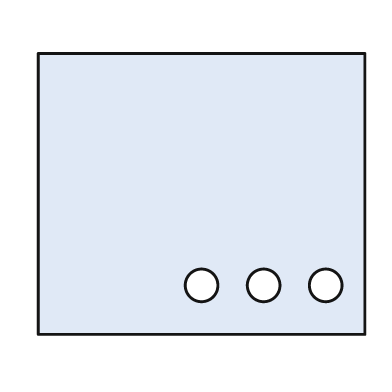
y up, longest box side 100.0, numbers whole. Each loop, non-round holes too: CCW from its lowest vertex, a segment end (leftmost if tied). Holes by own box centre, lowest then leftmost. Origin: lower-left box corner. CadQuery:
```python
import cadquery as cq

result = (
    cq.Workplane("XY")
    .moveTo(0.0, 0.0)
    .lineTo(100.0, 0.0)
    .lineTo(100.0, 86.0)
    .lineTo(0.0, 86.0)
    .close()
    .moveTo(50.0, 15.0)
    .circle(5.0)
    .moveTo(69.0, 15.0)
    .circle(5.0)
    .moveTo(88.0, 15.0)
    .circle(5.0)
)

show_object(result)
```